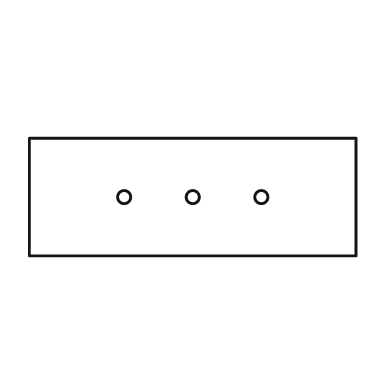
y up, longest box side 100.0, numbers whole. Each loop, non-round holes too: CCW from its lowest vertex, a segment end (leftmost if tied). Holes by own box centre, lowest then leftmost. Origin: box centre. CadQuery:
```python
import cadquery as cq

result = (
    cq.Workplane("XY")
    .moveTo(-50.0, -18.0)
    .lineTo(50.0, -18.0)
    .lineTo(50.0, 18.0)
    .lineTo(-50.0, 18.0)
    .close()
    .moveTo(-21.0, 0.0)
    .circle(2.0)
    .moveTo(0.0, 0.0)
    .circle(2.0)
    .moveTo(21.0, 0.0)
    .circle(2.0)
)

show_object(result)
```